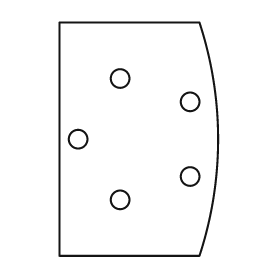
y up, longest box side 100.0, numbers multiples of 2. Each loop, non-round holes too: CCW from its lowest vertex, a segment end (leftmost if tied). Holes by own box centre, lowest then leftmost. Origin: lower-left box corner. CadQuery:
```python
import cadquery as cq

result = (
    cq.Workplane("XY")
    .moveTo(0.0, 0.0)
    .lineTo(60.0, 0.0)
    .threePointArc((68.0, 50.0), (60.0, 100.0))
    .lineTo(0.0, 100.0)
    .close()
    .moveTo(26.0, 24.0)
    .circle(4.0)
    .moveTo(56.0, 34.0)
    .circle(4.0)
    .moveTo(8.0, 50.0)
    .circle(4.0)
    .moveTo(56.0, 66.0)
    .circle(4.0)
    .moveTo(26.0, 76.0)
    .circle(4.0)
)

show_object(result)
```